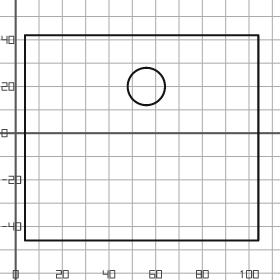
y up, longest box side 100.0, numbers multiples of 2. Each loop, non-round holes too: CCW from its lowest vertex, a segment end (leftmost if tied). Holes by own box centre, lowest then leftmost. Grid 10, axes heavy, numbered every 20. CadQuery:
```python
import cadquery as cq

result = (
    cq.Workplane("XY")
    .moveTo(4.0, -46.0)
    .lineTo(104.0, -46.0)
    .lineTo(104.0, 42.0)
    .lineTo(4.0, 42.0)
    .close()
    .moveTo(56.0, 20.0)
    .circle(8.0)
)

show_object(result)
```